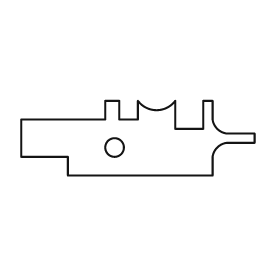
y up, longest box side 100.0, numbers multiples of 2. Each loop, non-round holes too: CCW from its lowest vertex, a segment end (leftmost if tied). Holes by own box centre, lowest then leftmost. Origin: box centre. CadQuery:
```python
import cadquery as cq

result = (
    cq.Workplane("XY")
    .moveTo(-30.0, -16.0)
    .lineTo(32.0, -16.0)
    .lineTo(32.0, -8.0)
    .threePointArc((34.0, -4.0), (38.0, -2.0))
    .lineTo(50.0, -2.0)
    .lineTo(50.0, 2.0)
    .lineTo(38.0, 2.0)
    .threePointArc((34.0, 4.0), (32.0, 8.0))
    .lineTo(32.0, 16.0)
    .lineTo(28.0, 16.0)
    .lineTo(28.0, 4.0)
    .lineTo(16.0, 4.0)
    .lineTo(16.0, 16.0)
    .threePointArc((8.0, 12.0), (0.0, 16.0))
    .lineTo(0.0, 8.0)
    .lineTo(-8.0, 8.0)
    .lineTo(-8.0, 16.0)
    .lineTo(-14.0, 16.0)
    .lineTo(-14.0, 8.0)
    .lineTo(-50.0, 8.0)
    .lineTo(-50.0, -8.0)
    .lineTo(-30.0, -8.0)
    .close()
    .moveTo(-10.0, -4.0)
    .circle(4.0)
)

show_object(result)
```